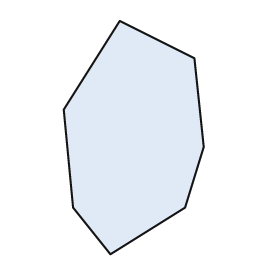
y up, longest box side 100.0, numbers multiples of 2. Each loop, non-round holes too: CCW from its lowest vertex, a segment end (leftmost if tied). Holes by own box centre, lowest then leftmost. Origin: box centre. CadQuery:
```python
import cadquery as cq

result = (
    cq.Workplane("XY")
    .moveTo(-10.0, -50.0)
    .lineTo(22.0, -30.0)
    .lineTo(30.0, -4.0)
    .lineTo(26.0, 34.0)
    .lineTo(-6.0, 50.0)
    .lineTo(-30.0, 12.0)
    .lineTo(-26.0, -30.0)
    .close()
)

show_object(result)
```